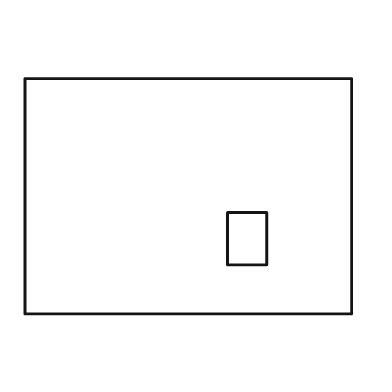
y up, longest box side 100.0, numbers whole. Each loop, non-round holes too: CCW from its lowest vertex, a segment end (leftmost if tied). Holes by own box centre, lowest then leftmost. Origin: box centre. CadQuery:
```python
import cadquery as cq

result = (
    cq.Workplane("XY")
    .moveTo(-50.0, -36.0)
    .lineTo(50.0, -36.0)
    .lineTo(50.0, 36.0)
    .lineTo(-50.0, 36.0)
    .close()
    .moveTo(12.0, -21.0)
    .lineTo(24.0, -21.0)
    .lineTo(24.0, -5.0)
    .lineTo(12.0, -5.0)
    .close()
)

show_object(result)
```